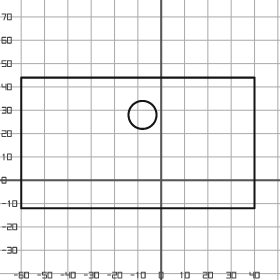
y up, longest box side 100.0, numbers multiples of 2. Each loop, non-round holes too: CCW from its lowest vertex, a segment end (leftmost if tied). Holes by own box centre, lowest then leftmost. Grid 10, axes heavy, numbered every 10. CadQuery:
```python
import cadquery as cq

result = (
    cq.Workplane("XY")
    .moveTo(-60.0, -12.0)
    .lineTo(40.0, -12.0)
    .lineTo(40.0, 44.0)
    .lineTo(-60.0, 44.0)
    .close()
    .moveTo(-8.0, 28.0)
    .circle(6.0)
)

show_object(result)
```